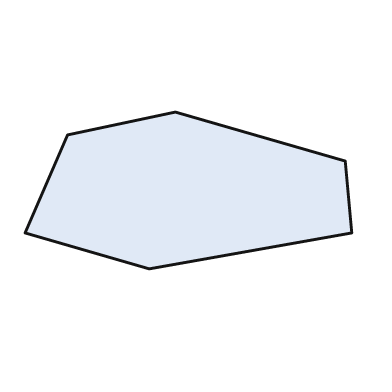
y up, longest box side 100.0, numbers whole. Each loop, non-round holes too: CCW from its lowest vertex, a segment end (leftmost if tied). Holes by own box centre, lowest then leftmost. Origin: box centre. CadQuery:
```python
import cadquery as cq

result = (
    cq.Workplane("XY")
    .moveTo(-12.0, -24.0)
    .lineTo(50.0, -13.0)
    .lineTo(48.0, 9.0)
    .lineTo(-4.0, 24.0)
    .lineTo(-37.0, 17.0)
    .lineTo(-50.0, -13.0)
    .close()
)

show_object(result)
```